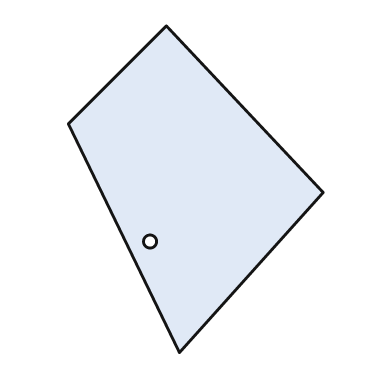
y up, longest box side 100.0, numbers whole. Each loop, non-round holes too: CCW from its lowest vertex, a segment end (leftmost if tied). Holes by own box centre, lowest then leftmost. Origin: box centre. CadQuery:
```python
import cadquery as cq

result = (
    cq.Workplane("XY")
    .moveTo(-5.0, -50.0)
    .lineTo(39.0, -1.0)
    .lineTo(-9.0, 50.0)
    .lineTo(-39.0, 20.0)
    .close()
    .moveTo(-14.0, -16.0)
    .circle(2.0)
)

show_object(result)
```